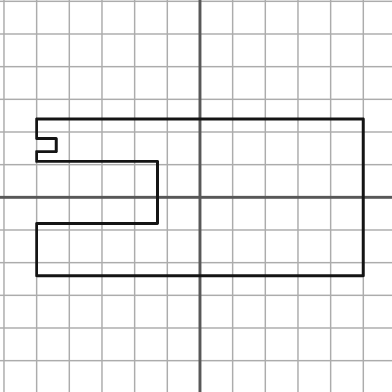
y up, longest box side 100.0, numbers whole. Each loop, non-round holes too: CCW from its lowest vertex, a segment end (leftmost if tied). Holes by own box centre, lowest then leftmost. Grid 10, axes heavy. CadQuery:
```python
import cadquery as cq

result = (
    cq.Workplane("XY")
    .moveTo(-50.0, -24.0)
    .lineTo(50.0, -24.0)
    .lineTo(50.0, 24.0)
    .lineTo(-50.0, 24.0)
    .lineTo(-50.0, 18.0)
    .lineTo(-44.0, 18.0)
    .lineTo(-44.0, 14.0)
    .lineTo(-50.0, 14.0)
    .lineTo(-50.0, 11.0)
    .lineTo(-13.0, 11.0)
    .lineTo(-13.0, -8.0)
    .lineTo(-50.0, -8.0)
    .close()
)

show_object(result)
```